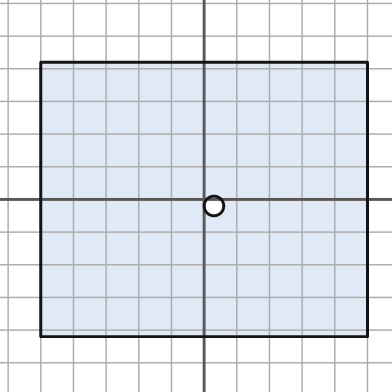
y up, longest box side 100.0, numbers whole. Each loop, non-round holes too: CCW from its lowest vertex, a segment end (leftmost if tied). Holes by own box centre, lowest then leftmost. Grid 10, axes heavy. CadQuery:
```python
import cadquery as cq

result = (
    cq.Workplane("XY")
    .moveTo(-50.0, -42.0)
    .lineTo(50.0, -42.0)
    .lineTo(50.0, 42.0)
    .lineTo(-50.0, 42.0)
    .close()
    .moveTo(3.0, -2.0)
    .circle(3.0)
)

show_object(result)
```